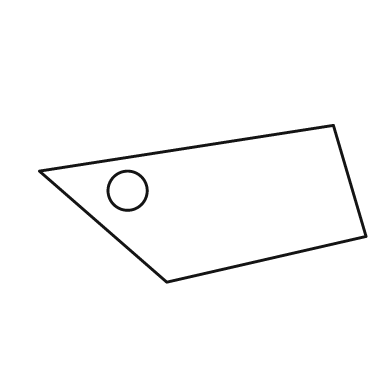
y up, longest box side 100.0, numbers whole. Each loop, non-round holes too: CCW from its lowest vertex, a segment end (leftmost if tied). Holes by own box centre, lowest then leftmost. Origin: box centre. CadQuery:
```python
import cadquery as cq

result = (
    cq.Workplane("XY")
    .moveTo(-11.0, -24.0)
    .lineTo(50.0, -10.0)
    .lineTo(40.0, 24.0)
    .lineTo(-50.0, 10.0)
    .close()
    .moveTo(-23.0, 4.0)
    .circle(6.0)
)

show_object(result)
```